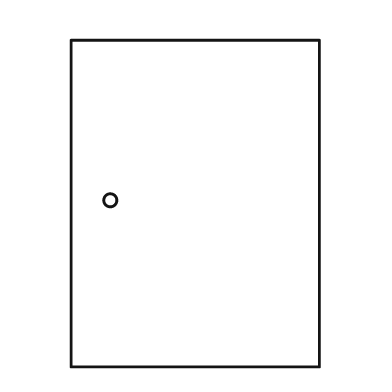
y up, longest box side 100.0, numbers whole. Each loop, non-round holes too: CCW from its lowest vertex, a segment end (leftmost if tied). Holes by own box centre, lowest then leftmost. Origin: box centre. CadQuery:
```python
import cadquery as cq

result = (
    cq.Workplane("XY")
    .moveTo(-38.0, -50.0)
    .lineTo(38.0, -50.0)
    .lineTo(38.0, 50.0)
    .lineTo(-38.0, 50.0)
    .close()
    .moveTo(-26.0, 1.0)
    .circle(2.0)
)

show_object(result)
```